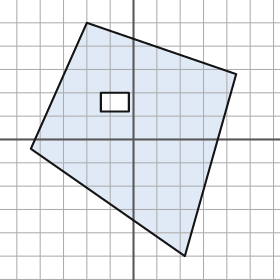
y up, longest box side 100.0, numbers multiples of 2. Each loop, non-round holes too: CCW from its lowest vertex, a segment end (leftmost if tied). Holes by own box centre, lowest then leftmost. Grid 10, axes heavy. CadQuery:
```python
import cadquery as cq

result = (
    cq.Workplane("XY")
    .moveTo(22.0, -50.0)
    .lineTo(44.0, 28.0)
    .lineTo(-20.0, 50.0)
    .lineTo(-44.0, -4.0)
    .close()
    .moveTo(-14.0, 12.0)
    .lineTo(-2.0, 12.0)
    .lineTo(-2.0, 20.0)
    .lineTo(-14.0, 20.0)
    .close()
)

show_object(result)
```